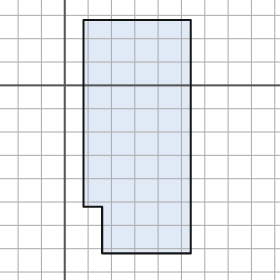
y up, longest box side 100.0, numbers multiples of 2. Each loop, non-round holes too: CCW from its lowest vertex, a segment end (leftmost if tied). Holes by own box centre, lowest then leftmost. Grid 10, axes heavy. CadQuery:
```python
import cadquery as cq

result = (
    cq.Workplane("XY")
    .moveTo(16.0, -72.0)
    .lineTo(54.0, -72.0)
    .lineTo(54.0, 28.0)
    .lineTo(8.0, 28.0)
    .lineTo(8.0, -52.0)
    .lineTo(16.0, -52.0)
    .close()
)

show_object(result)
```